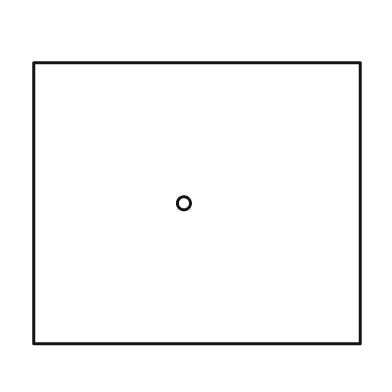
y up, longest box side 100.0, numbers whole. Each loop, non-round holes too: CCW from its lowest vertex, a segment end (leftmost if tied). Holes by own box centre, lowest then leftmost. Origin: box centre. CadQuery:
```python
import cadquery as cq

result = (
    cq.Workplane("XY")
    .moveTo(-50.0, -43.0)
    .lineTo(50.0, -43.0)
    .lineTo(50.0, 43.0)
    .lineTo(-50.0, 43.0)
    .close()
    .moveTo(-4.0, 0.0)
    .circle(2.0)
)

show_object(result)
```